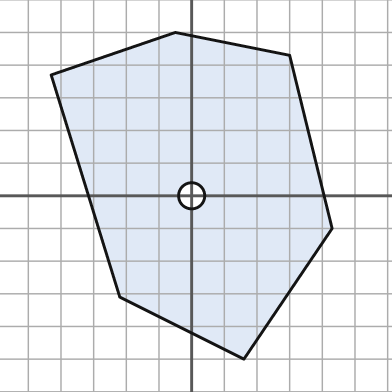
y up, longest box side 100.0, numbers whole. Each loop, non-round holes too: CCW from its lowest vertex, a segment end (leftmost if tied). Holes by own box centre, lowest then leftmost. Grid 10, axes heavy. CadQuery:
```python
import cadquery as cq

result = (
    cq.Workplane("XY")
    .moveTo(16.0, -50.0)
    .lineTo(43.0, -10.0)
    .lineTo(30.0, 43.0)
    .lineTo(-5.0, 50.0)
    .lineTo(-43.0, 37.0)
    .lineTo(-22.0, -31.0)
    .close()
    .moveTo(0.0, 0.0)
    .circle(4.0)
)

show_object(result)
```